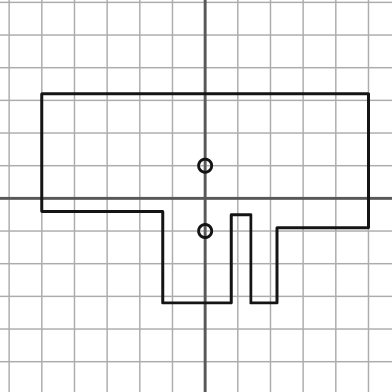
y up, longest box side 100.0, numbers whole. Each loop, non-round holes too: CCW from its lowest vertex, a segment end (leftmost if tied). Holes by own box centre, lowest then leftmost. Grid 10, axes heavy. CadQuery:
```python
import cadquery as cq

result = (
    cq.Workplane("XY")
    .moveTo(-13.0, -32.0)
    .lineTo(8.0, -32.0)
    .lineTo(8.0, -5.0)
    .lineTo(14.0, -5.0)
    .lineTo(14.0, -32.0)
    .lineTo(22.0, -32.0)
    .lineTo(22.0, -9.0)
    .lineTo(50.0, -9.0)
    .lineTo(50.0, 32.0)
    .lineTo(-50.0, 32.0)
    .lineTo(-50.0, -4.0)
    .lineTo(-13.0, -4.0)
    .close()
    .moveTo(0.0, -10.0)
    .circle(2.0)
    .moveTo(0.0, 10.0)
    .circle(2.0)
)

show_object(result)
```